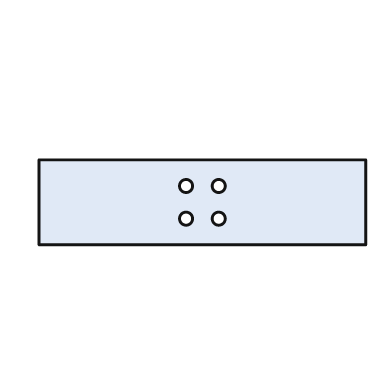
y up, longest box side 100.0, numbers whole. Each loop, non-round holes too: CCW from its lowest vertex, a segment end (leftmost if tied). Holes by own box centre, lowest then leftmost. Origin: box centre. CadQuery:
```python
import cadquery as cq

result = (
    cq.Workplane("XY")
    .moveTo(-50.0, -13.0)
    .lineTo(50.0, -13.0)
    .lineTo(50.0, 13.0)
    .lineTo(-50.0, 13.0)
    .close()
    .moveTo(-5.0, -5.0)
    .circle(2.0)
    .moveTo(5.0, -5.0)
    .circle(2.0)
    .moveTo(-5.0, 5.0)
    .circle(2.0)
    .moveTo(5.0, 5.0)
    .circle(2.0)
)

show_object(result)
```